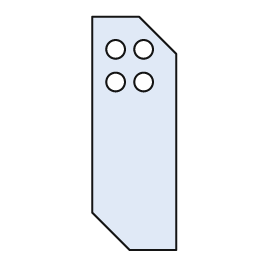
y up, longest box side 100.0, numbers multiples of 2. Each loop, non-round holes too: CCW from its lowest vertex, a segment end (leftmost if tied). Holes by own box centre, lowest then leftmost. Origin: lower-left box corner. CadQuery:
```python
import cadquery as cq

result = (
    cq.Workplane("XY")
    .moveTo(16.0, 0.0)
    .lineTo(36.0, 0.0)
    .lineTo(36.0, 84.0)
    .lineTo(20.0, 100.0)
    .lineTo(0.0, 100.0)
    .lineTo(0.0, 16.0)
    .close()
    .moveTo(10.0, 72.0)
    .circle(4.0)
    .moveTo(22.0, 72.0)
    .circle(4.0)
    .moveTo(10.0, 86.0)
    .circle(4.0)
    .moveTo(22.0, 86.0)
    .circle(4.0)
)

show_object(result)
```